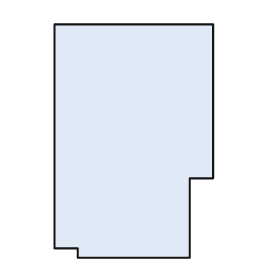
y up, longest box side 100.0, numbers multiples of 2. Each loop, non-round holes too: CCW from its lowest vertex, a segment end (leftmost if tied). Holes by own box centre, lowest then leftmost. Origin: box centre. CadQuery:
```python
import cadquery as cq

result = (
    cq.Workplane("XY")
    .moveTo(-24.0, -50.0)
    .lineTo(24.0, -50.0)
    .lineTo(24.0, -16.0)
    .lineTo(34.0, -16.0)
    .lineTo(34.0, 50.0)
    .lineTo(-34.0, 50.0)
    .lineTo(-34.0, -46.0)
    .lineTo(-24.0, -46.0)
    .close()
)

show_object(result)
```